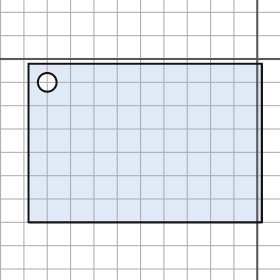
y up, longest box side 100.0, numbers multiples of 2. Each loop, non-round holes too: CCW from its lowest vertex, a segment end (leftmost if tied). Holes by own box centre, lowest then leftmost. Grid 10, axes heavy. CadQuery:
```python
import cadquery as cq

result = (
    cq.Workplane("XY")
    .moveTo(-98.0, -70.0)
    .lineTo(2.0, -70.0)
    .lineTo(2.0, -2.0)
    .lineTo(-98.0, -2.0)
    .close()
    .moveTo(-90.0, -10.0)
    .circle(4.0)
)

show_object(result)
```